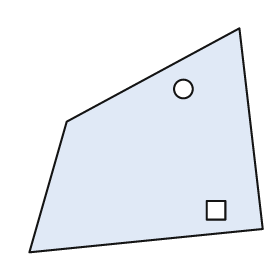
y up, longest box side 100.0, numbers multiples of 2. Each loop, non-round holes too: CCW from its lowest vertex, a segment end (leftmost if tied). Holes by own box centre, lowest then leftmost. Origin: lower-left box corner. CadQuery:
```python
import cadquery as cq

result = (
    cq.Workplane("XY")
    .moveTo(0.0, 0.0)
    .lineTo(100.0, 10.0)
    .lineTo(90.0, 96.0)
    .lineTo(16.0, 56.0)
    .close()
    .moveTo(76.0, 14.0)
    .lineTo(84.0, 14.0)
    .lineTo(84.0, 22.0)
    .lineTo(76.0, 22.0)
    .close()
    .moveTo(66.0, 70.0)
    .circle(4.0)
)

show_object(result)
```